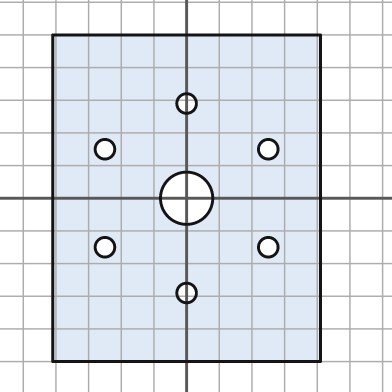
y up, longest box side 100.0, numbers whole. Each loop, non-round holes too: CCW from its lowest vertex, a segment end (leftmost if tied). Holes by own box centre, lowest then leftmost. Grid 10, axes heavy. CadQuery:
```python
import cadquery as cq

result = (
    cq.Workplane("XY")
    .moveTo(-41.0, -50.0)
    .lineTo(41.0, -50.0)
    .lineTo(41.0, 50.0)
    .lineTo(-41.0, 50.0)
    .close()
    .moveTo(0.0, -29.0)
    .circle(3.0)
    .moveTo(-25.0, -15.0)
    .circle(3.0)
    .moveTo(25.0, -15.0)
    .circle(3.0)
    .moveTo(0.0, 0.0)
    .circle(8.0)
    .moveTo(-25.0, 15.0)
    .circle(3.0)
    .moveTo(25.0, 15.0)
    .circle(3.0)
    .moveTo(0.0, 29.0)
    .circle(3.0)
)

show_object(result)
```